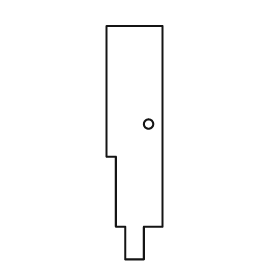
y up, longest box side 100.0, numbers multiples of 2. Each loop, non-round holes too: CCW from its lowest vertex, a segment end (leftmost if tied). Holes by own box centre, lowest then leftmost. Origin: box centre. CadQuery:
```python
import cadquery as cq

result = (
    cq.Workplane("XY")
    .moveTo(-4.0, -50.0)
    .lineTo(4.0, -50.0)
    .lineTo(4.0, -36.0)
    .lineTo(12.0, -36.0)
    .lineTo(12.0, 50.0)
    .lineTo(-12.0, 50.0)
    .lineTo(-12.0, -6.0)
    .lineTo(-8.0, -6.0)
    .lineTo(-8.0, -36.0)
    .lineTo(-4.0, -36.0)
    .close()
    .moveTo(6.0, 8.0)
    .circle(2.0)
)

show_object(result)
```